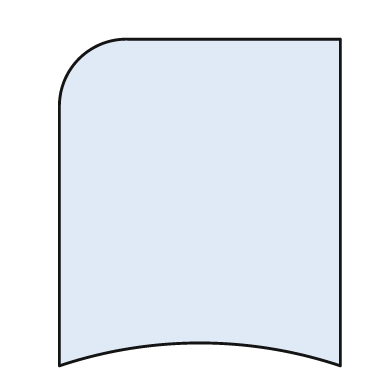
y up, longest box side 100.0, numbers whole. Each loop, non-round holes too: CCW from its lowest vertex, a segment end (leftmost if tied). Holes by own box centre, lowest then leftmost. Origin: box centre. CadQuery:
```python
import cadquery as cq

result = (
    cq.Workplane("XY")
    .moveTo(-43.0, -50.0)
    .threePointArc((0.0, -43.0), (43.0, -50.0))
    .lineTo(43.0, 50.0)
    .lineTo(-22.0, 50.0)
    .threePointArc((-37.0, 44.0), (-43.0, 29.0))
    .close()
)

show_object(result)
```